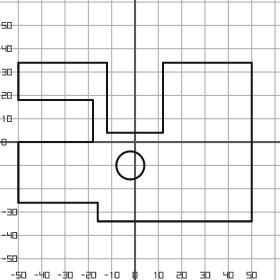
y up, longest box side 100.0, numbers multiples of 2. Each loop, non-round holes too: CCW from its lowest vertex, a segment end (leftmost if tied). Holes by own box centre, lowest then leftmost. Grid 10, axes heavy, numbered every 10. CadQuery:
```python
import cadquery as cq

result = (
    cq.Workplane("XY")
    .moveTo(-16.0, -34.0)
    .lineTo(50.0, -34.0)
    .lineTo(50.0, 34.0)
    .lineTo(12.0, 34.0)
    .lineTo(12.0, 4.0)
    .lineTo(-12.0, 4.0)
    .lineTo(-12.0, 34.0)
    .lineTo(-50.0, 34.0)
    .lineTo(-50.0, 18.0)
    .lineTo(-18.0, 18.0)
    .lineTo(-18.0, 0.0)
    .lineTo(-50.0, 0.0)
    .lineTo(-50.0, -26.0)
    .lineTo(-16.0, -26.0)
    .close()
    .moveTo(-2.0, -10.0)
    .circle(6.0)
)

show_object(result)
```